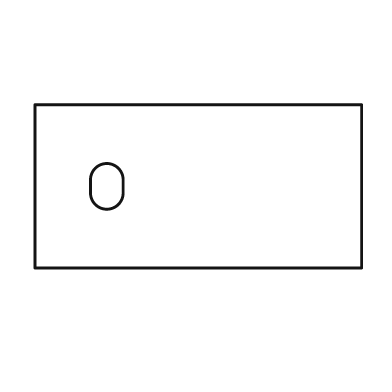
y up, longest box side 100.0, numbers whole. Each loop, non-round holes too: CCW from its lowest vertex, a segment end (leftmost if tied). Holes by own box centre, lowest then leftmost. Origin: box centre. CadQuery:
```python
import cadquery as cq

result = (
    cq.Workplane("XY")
    .moveTo(-50.0, -25.0)
    .lineTo(50.0, -25.0)
    .lineTo(50.0, 25.0)
    .lineTo(-50.0, 25.0)
    .close()
    .moveTo(-33.0, -2.0)
    .threePointArc((-28.0, -7.0), (-23.0, -2.0))
    .lineTo(-23.0, 2.0)
    .threePointArc((-28.0, 7.0), (-33.0, 2.0))
    .close()
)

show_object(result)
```